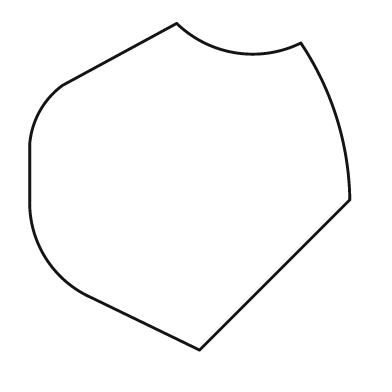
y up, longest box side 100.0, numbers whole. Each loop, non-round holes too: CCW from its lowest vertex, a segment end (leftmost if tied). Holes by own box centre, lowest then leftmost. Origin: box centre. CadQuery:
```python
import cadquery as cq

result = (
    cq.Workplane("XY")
    .moveTo(3.0, -50.0)
    .lineTo(49.0, -4.0)
    .threePointArc((45.0, 21.0), (34.0, 44.0))
    .threePointArc((14.0, 41.0), (-4.0, 50.0))
    .lineTo(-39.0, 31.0)
    .threePointArc((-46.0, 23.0), (-49.0, 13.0))
    .lineTo(-49.0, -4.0)
    .threePointArc((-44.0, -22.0), (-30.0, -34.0))
    .close()
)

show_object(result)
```